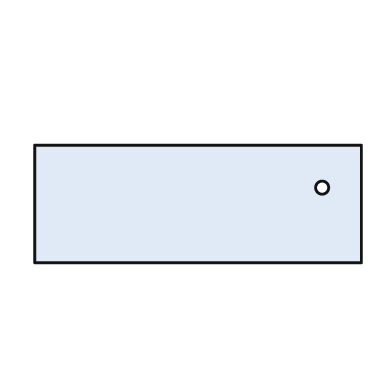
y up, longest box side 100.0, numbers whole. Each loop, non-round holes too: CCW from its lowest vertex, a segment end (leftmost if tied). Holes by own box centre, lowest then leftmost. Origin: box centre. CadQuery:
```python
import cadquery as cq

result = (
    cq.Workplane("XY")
    .moveTo(-50.0, -18.0)
    .lineTo(50.0, -18.0)
    .lineTo(50.0, 18.0)
    .lineTo(-50.0, 18.0)
    .close()
    .moveTo(38.0, 5.0)
    .circle(2.0)
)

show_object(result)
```